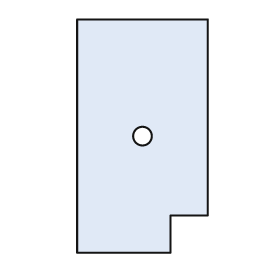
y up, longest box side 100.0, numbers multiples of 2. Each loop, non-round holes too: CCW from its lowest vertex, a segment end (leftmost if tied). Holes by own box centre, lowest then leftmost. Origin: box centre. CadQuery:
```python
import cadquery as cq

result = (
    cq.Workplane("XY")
    .moveTo(-28.0, -50.0)
    .lineTo(12.0, -50.0)
    .lineTo(12.0, -34.0)
    .lineTo(28.0, -34.0)
    .lineTo(28.0, 50.0)
    .lineTo(-28.0, 50.0)
    .close()
    .moveTo(0.0, 0.0)
    .circle(4.0)
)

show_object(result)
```